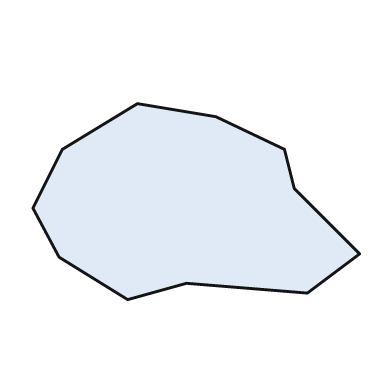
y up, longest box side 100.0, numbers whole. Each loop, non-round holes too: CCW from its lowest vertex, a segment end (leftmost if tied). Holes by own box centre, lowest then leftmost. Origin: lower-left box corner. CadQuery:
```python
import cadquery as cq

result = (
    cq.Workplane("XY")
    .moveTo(29.0, 0.0)
    .lineTo(47.0, 5.0)
    .lineTo(84.0, 2.0)
    .lineTo(100.0, 14.0)
    .lineTo(80.0, 34.0)
    .lineTo(77.0, 46.0)
    .lineTo(56.0, 56.0)
    .lineTo(32.0, 60.0)
    .lineTo(9.0, 46.0)
    .lineTo(0.0, 28.0)
    .lineTo(8.0, 13.0)
    .close()
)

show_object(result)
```